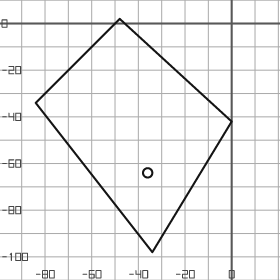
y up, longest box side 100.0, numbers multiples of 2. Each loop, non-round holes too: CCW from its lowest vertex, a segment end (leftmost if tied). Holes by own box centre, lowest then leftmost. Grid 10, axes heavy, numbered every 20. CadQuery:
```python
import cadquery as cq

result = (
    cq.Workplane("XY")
    .moveTo(-34.0, -98.0)
    .lineTo(0.0, -42.0)
    .lineTo(-48.0, 2.0)
    .lineTo(-84.0, -34.0)
    .close()
    .moveTo(-36.0, -64.0)
    .circle(2.0)
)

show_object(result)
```